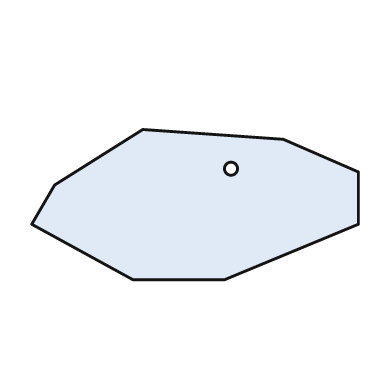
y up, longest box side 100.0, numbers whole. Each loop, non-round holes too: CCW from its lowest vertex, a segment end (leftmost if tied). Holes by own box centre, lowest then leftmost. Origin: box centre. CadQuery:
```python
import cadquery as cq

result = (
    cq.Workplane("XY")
    .moveTo(-19.0, -23.0)
    .lineTo(9.0, -23.0)
    .lineTo(50.0, -6.0)
    .lineTo(50.0, 10.0)
    .lineTo(27.0, 20.0)
    .lineTo(-16.0, 23.0)
    .lineTo(-43.0, 6.0)
    .lineTo(-50.0, -6.0)
    .close()
    .moveTo(11.0, 11.0)
    .circle(2.0)
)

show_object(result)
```